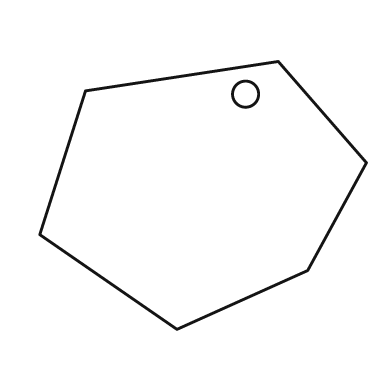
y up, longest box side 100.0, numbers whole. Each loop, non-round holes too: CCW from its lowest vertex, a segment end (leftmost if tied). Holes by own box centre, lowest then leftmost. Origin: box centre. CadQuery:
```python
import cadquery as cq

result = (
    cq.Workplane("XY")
    .moveTo(-8.0, -41.0)
    .lineTo(32.0, -23.0)
    .lineTo(50.0, 10.0)
    .lineTo(23.0, 41.0)
    .lineTo(-36.0, 32.0)
    .lineTo(-50.0, -12.0)
    .close()
    .moveTo(13.0, 31.0)
    .circle(4.0)
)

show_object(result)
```